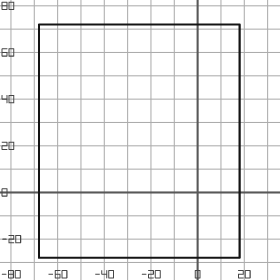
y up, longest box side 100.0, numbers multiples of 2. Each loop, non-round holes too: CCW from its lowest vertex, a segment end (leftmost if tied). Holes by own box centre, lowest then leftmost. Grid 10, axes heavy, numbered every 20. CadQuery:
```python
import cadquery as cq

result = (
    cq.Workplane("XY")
    .moveTo(-68.0, -28.0)
    .lineTo(18.0, -28.0)
    .lineTo(18.0, 72.0)
    .lineTo(-68.0, 72.0)
    .close()
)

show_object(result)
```